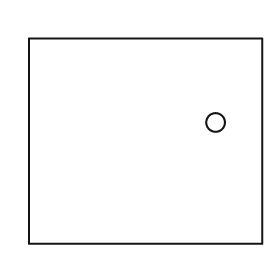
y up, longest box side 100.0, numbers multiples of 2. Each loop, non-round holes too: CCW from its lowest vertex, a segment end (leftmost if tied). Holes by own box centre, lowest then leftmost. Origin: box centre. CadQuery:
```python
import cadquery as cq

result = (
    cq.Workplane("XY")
    .moveTo(-50.0, -44.0)
    .lineTo(50.0, -44.0)
    .lineTo(50.0, 44.0)
    .lineTo(-50.0, 44.0)
    .close()
    .moveTo(30.0, 8.0)
    .circle(4.0)
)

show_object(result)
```